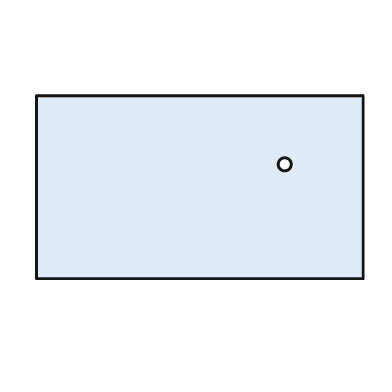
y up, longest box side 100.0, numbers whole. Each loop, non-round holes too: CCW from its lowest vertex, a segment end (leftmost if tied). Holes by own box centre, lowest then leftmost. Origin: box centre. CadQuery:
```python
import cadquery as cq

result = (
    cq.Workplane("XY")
    .moveTo(-50.0, -28.0)
    .lineTo(50.0, -28.0)
    .lineTo(50.0, 28.0)
    .lineTo(-50.0, 28.0)
    .close()
    .moveTo(26.0, 7.0)
    .circle(2.0)
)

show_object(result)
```